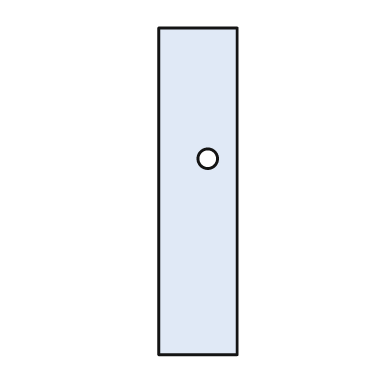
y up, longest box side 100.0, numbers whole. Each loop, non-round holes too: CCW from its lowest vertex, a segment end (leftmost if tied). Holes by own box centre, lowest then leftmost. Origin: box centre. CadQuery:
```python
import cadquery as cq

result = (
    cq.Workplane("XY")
    .moveTo(-12.0, -50.0)
    .lineTo(12.0, -50.0)
    .lineTo(12.0, 50.0)
    .lineTo(-12.0, 50.0)
    .close()
    .moveTo(3.0, 10.0)
    .circle(3.0)
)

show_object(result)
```